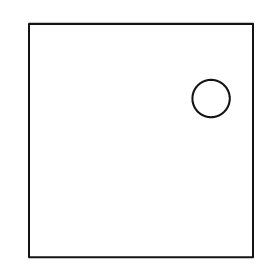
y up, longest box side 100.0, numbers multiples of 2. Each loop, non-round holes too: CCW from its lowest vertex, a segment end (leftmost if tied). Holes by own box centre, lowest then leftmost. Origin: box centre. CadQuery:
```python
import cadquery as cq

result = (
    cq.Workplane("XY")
    .moveTo(-48.0, -50.0)
    .lineTo(48.0, -50.0)
    .lineTo(48.0, 50.0)
    .lineTo(-48.0, 50.0)
    .close()
    .moveTo(30.0, 18.0)
    .circle(8.0)
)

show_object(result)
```